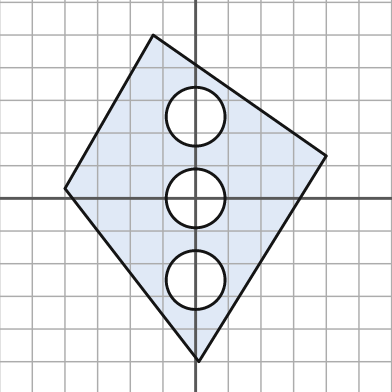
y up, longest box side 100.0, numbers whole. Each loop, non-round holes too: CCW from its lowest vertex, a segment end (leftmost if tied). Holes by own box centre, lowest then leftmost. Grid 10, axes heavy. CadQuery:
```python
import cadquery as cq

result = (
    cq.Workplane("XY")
    .moveTo(1.0, -50.0)
    .lineTo(40.0, 13.0)
    .lineTo(-13.0, 50.0)
    .lineTo(-40.0, 3.0)
    .close()
    .moveTo(0.0, -25.0)
    .circle(9.0)
    .moveTo(0.0, 0.0)
    .circle(9.0)
    .moveTo(0.0, 25.0)
    .circle(9.0)
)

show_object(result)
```